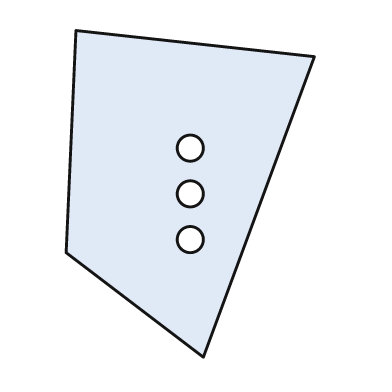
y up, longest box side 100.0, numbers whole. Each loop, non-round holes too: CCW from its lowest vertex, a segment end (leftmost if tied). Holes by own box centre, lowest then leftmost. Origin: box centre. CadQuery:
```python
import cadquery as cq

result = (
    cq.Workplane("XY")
    .moveTo(4.0, -50.0)
    .lineTo(38.0, 42.0)
    .lineTo(-35.0, 50.0)
    .lineTo(-38.0, -18.0)
    .close()
    .moveTo(0.0, -14.0)
    .circle(4.0)
    .moveTo(0.0, 0.0)
    .circle(4.0)
    .moveTo(0.0, 14.0)
    .circle(4.0)
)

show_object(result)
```